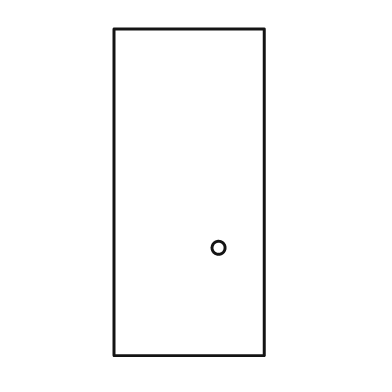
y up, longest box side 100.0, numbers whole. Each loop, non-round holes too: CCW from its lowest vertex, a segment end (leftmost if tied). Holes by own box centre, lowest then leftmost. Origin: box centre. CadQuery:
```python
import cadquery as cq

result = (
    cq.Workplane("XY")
    .moveTo(-23.0, -50.0)
    .lineTo(23.0, -50.0)
    .lineTo(23.0, 50.0)
    .lineTo(-23.0, 50.0)
    .close()
    .moveTo(9.0, -17.0)
    .circle(2.0)
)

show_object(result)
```